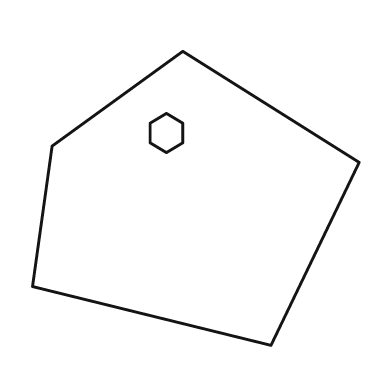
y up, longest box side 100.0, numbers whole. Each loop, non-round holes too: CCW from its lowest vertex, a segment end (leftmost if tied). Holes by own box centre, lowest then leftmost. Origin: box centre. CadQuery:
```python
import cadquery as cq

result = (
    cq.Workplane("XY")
    .moveTo(23.0, -45.0)
    .lineTo(50.0, 11.0)
    .lineTo(-4.0, 45.0)
    .lineTo(-44.0, 16.0)
    .lineTo(-50.0, -27.0)
    .close()
    .moveTo(-9.0, 14.0)
    .lineTo(-4.0, 17.0)
    .lineTo(-4.0, 23.0)
    .lineTo(-9.0, 26.0)
    .lineTo(-14.0, 23.0)
    .lineTo(-14.0, 17.0)
    .close()
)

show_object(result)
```